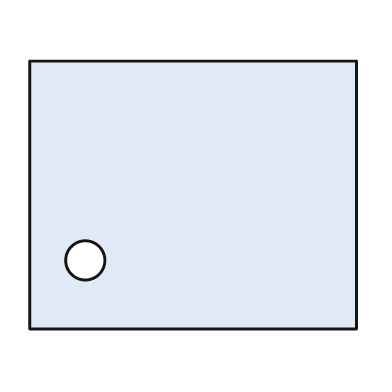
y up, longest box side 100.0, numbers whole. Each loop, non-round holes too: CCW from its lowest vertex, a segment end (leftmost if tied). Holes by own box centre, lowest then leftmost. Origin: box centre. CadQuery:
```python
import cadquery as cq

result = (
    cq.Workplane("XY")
    .moveTo(-50.0, -41.0)
    .lineTo(50.0, -41.0)
    .lineTo(50.0, 41.0)
    .lineTo(-50.0, 41.0)
    .close()
    .moveTo(-33.0, -20.0)
    .circle(6.0)
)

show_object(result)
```